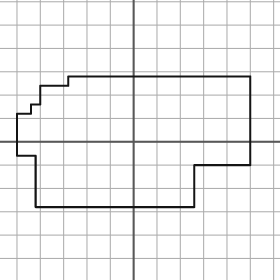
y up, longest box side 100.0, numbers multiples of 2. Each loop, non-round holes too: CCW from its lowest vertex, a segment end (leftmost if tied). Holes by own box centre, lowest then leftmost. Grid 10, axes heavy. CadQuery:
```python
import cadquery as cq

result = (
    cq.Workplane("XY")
    .moveTo(-42.0, -28.0)
    .lineTo(26.0, -28.0)
    .lineTo(26.0, -10.0)
    .lineTo(50.0, -10.0)
    .lineTo(50.0, 28.0)
    .lineTo(-28.0, 28.0)
    .lineTo(-28.0, 24.0)
    .lineTo(-40.0, 24.0)
    .lineTo(-40.0, 16.0)
    .lineTo(-44.0, 16.0)
    .lineTo(-44.0, 12.0)
    .lineTo(-50.0, 12.0)
    .lineTo(-50.0, -6.0)
    .lineTo(-42.0, -6.0)
    .close()
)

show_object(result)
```